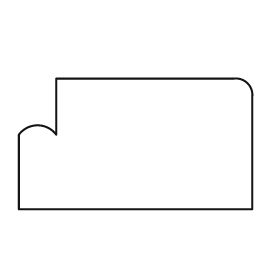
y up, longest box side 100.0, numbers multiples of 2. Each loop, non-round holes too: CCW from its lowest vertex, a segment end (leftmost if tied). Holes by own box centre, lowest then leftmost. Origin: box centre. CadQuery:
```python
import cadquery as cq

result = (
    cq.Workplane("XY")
    .moveTo(-50.0, -28.0)
    .lineTo(50.0, -28.0)
    .lineTo(50.0, 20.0)
    .threePointArc((48.0, 26.0), (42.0, 28.0))
    .lineTo(-34.0, 28.0)
    .lineTo(-34.0, 4.0)
    .threePointArc((-42.0, 8.0), (-50.0, 4.0))
    .close()
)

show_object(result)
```